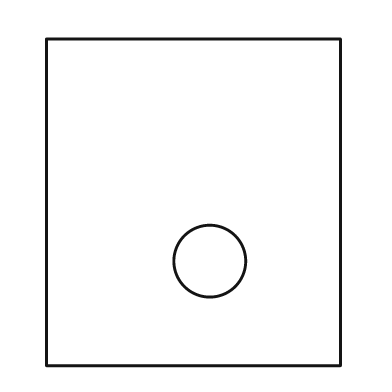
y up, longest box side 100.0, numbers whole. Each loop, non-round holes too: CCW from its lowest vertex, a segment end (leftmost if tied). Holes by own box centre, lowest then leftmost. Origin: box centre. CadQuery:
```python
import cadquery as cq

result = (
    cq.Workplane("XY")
    .moveTo(-45.0, -50.0)
    .lineTo(45.0, -50.0)
    .lineTo(45.0, 50.0)
    .lineTo(-45.0, 50.0)
    .close()
    .moveTo(5.0, -18.0)
    .circle(11.0)
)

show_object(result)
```